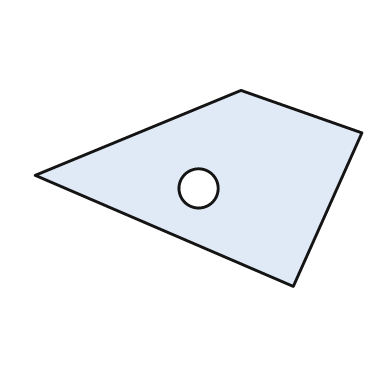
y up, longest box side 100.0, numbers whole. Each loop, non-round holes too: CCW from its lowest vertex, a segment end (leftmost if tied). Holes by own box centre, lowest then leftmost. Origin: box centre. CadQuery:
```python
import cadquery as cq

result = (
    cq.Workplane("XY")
    .moveTo(29.0, -30.0)
    .lineTo(50.0, 17.0)
    .lineTo(13.0, 30.0)
    .lineTo(-50.0, 4.0)
    .close()
    .moveTo(0.0, 0.0)
    .circle(6.0)
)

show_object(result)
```